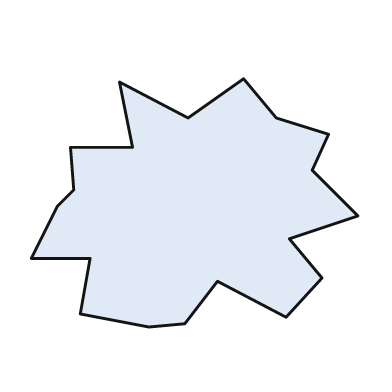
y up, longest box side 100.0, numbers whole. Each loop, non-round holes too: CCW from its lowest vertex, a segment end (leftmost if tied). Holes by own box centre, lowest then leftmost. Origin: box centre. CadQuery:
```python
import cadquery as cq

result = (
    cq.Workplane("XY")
    .moveTo(-14.0, -38.0)
    .lineTo(-3.0, -37.0)
    .lineTo(7.0, -24.0)
    .lineTo(28.0, -35.0)
    .lineTo(39.0, -23.0)
    .lineTo(29.0, -11.0)
    .lineTo(50.0, -4.0)
    .lineTo(36.0, 10.0)
    .lineTo(41.0, 21.0)
    .lineTo(25.0, 26.0)
    .lineTo(15.0, 38.0)
    .lineTo(-2.0, 26.0)
    .lineTo(-23.0, 37.0)
    .lineTo(-19.0, 17.0)
    .lineTo(-38.0, 17.0)
    .lineTo(-37.0, 4.0)
    .lineTo(-42.0, -1.0)
    .lineTo(-50.0, -17.0)
    .lineTo(-32.0, -17.0)
    .lineTo(-35.0, -34.0)
    .close()
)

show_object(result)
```